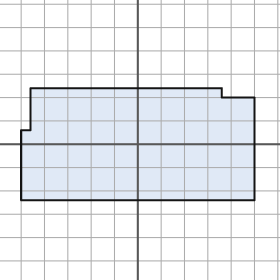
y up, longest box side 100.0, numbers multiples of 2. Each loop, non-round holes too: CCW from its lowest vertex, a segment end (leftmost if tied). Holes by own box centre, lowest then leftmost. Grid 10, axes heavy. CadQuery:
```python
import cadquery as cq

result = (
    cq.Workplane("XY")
    .moveTo(-50.0, -24.0)
    .lineTo(50.0, -24.0)
    .lineTo(50.0, 20.0)
    .lineTo(36.0, 20.0)
    .lineTo(36.0, 24.0)
    .lineTo(-46.0, 24.0)
    .lineTo(-46.0, 6.0)
    .lineTo(-50.0, 6.0)
    .close()
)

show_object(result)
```